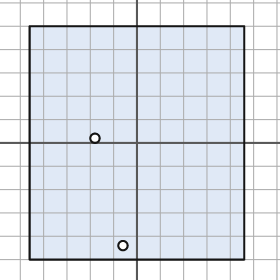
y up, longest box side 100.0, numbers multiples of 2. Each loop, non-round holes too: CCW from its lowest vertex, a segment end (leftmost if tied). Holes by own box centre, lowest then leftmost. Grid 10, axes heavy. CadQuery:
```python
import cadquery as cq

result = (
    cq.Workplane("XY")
    .moveTo(-46.0, -50.0)
    .lineTo(46.0, -50.0)
    .lineTo(46.0, 50.0)
    .lineTo(-46.0, 50.0)
    .close()
    .moveTo(-6.0, -44.0)
    .circle(2.0)
    .moveTo(-18.0, 2.0)
    .circle(2.0)
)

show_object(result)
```